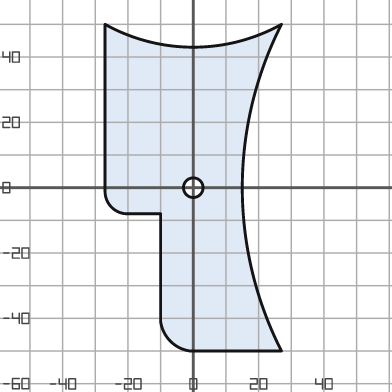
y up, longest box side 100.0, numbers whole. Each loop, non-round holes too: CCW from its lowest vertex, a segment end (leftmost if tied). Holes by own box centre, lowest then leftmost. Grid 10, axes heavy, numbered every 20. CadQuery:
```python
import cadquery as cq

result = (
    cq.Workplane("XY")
    .moveTo(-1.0, -50.0)
    .lineTo(27.0, -50.0)
    .threePointArc((15.0, 0.0), (27.0, 50.0))
    .threePointArc((0.0, 43.0), (-27.0, 50.0))
    .lineTo(-27.0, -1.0)
    .threePointArc((-25.0, -6.0), (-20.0, -8.0))
    .lineTo(-10.0, -8.0)
    .lineTo(-10.0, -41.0)
    .threePointArc((-7.0, -47.0), (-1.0, -50.0))
    .close()
    .moveTo(0.0, 0.0)
    .circle(3.0)
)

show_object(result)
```